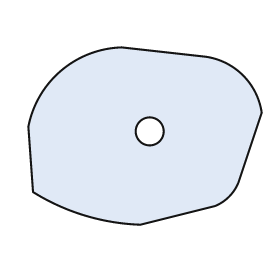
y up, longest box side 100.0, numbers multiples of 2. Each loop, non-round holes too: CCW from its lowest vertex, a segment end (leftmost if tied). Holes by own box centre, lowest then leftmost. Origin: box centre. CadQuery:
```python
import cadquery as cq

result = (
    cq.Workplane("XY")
    .moveTo(-2.0, -38.0)
    .lineTo(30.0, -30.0)
    .threePointArc((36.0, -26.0), (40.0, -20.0))
    .lineTo(50.0, 10.0)
    .threePointArc((42.0, 26.0), (26.0, 34.0))
    .lineTo(-10.0, 38.0)
    .threePointArc((-36.0, 28.0), (-50.0, 4.0))
    .lineTo(-48.0, -24.0)
    .threePointArc((-26.0, -34.0), (-2.0, -38.0))
    .close()
    .moveTo(2.0, 2.0)
    .circle(6.0)
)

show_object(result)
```